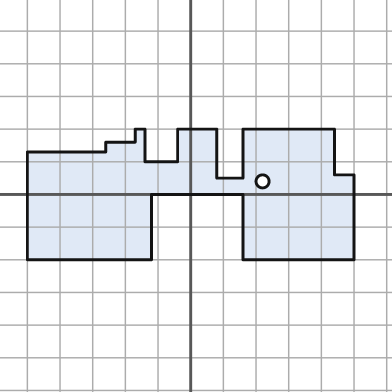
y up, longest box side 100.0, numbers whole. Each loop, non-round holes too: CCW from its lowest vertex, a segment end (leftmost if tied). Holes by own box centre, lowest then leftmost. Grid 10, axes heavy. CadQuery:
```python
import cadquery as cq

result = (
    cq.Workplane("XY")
    .moveTo(-50.0, -20.0)
    .lineTo(-12.0, -20.0)
    .lineTo(-12.0, 0.0)
    .lineTo(16.0, 0.0)
    .lineTo(16.0, -20.0)
    .lineTo(50.0, -20.0)
    .lineTo(50.0, 6.0)
    .lineTo(44.0, 6.0)
    .lineTo(44.0, 20.0)
    .lineTo(16.0, 20.0)
    .lineTo(16.0, 5.0)
    .lineTo(8.0, 5.0)
    .lineTo(8.0, 20.0)
    .lineTo(-4.0, 20.0)
    .lineTo(-4.0, 10.0)
    .lineTo(-14.0, 10.0)
    .lineTo(-14.0, 20.0)
    .lineTo(-17.0, 20.0)
    .lineTo(-17.0, 16.0)
    .lineTo(-26.0, 16.0)
    .lineTo(-26.0, 13.0)
    .lineTo(-50.0, 13.0)
    .close()
    .moveTo(22.0, 4.0)
    .circle(2.0)
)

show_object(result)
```